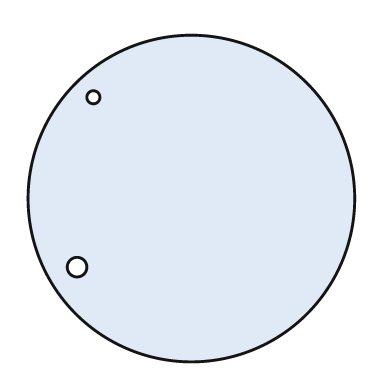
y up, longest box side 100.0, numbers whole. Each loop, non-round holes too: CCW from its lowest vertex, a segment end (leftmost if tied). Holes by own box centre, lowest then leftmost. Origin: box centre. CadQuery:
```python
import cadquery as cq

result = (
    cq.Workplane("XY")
    .moveTo(0.0, 0.0)
    .circle(50.0)
    .moveTo(-35.0, -21.0)
    .circle(3.0)
    .moveTo(-30.0, 31.0)
    .circle(2.0)
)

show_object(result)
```